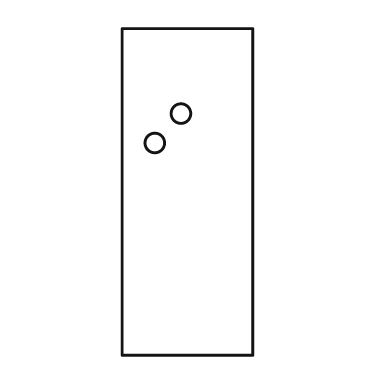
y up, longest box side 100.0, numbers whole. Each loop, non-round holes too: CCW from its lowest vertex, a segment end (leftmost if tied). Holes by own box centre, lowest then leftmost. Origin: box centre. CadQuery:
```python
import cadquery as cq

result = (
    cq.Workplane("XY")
    .moveTo(-20.0, -50.0)
    .lineTo(20.0, -50.0)
    .lineTo(20.0, 50.0)
    .lineTo(-20.0, 50.0)
    .close()
    .moveTo(-10.0, 15.0)
    .circle(3.0)
    .moveTo(-2.0, 24.0)
    .circle(3.0)
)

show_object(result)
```